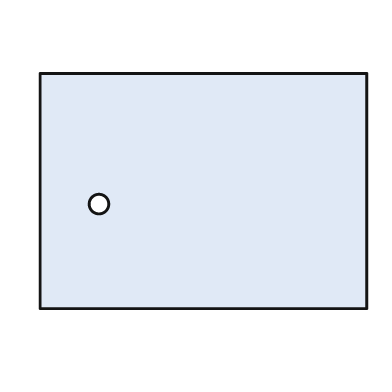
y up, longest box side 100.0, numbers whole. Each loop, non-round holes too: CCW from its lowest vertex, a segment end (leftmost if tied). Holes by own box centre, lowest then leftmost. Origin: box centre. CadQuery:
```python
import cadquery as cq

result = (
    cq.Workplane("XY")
    .moveTo(-50.0, -36.0)
    .lineTo(50.0, -36.0)
    .lineTo(50.0, 36.0)
    .lineTo(-50.0, 36.0)
    .close()
    .moveTo(-32.0, -4.0)
    .circle(3.0)
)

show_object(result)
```